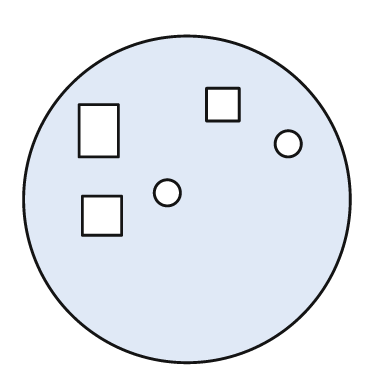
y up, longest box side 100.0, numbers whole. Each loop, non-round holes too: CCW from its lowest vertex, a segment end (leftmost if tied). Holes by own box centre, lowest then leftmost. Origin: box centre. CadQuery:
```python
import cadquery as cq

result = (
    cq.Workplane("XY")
    .moveTo(0.0, 0.0)
    .circle(50.0)
    .moveTo(-32.0, -11.0)
    .lineTo(-20.0, -11.0)
    .lineTo(-20.0, 1.0)
    .lineTo(-32.0, 1.0)
    .close()
    .moveTo(-6.0, 2.0)
    .circle(4.0)
    .moveTo(31.0, 17.0)
    .circle(4.0)
    .moveTo(-33.0, 13.0)
    .lineTo(-21.0, 13.0)
    .lineTo(-21.0, 29.0)
    .lineTo(-33.0, 29.0)
    .close()
    .moveTo(6.0, 24.0)
    .lineTo(16.0, 24.0)
    .lineTo(16.0, 34.0)
    .lineTo(6.0, 34.0)
    .close()
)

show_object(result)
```